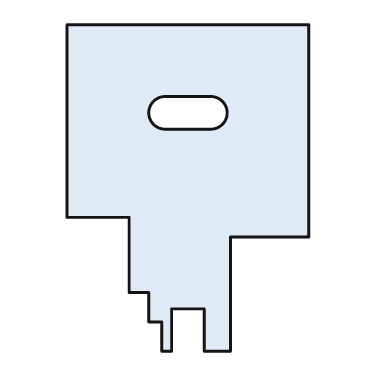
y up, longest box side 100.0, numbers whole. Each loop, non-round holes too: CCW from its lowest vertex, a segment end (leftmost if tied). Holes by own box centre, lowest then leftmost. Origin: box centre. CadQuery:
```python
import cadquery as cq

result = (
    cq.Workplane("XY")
    .moveTo(-8.0, -50.0)
    .lineTo(-5.0, -50.0)
    .lineTo(-5.0, -37.0)
    .lineTo(5.0, -37.0)
    .lineTo(5.0, -50.0)
    .lineTo(13.0, -50.0)
    .lineTo(13.0, -15.0)
    .lineTo(37.0, -15.0)
    .lineTo(37.0, 50.0)
    .lineTo(-37.0, 50.0)
    .lineTo(-37.0, -9.0)
    .lineTo(-18.0, -9.0)
    .lineTo(-18.0, -32.0)
    .lineTo(-12.0, -32.0)
    .lineTo(-12.0, -41.0)
    .lineTo(-8.0, -41.0)
    .close()
    .moveTo(-7.0, 18.0)
    .lineTo(7.0, 18.0)
    .threePointArc((12.0, 23.0), (7.0, 28.0))
    .lineTo(-7.0, 28.0)
    .threePointArc((-12.0, 23.0), (-7.0, 18.0))
    .close()
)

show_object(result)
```